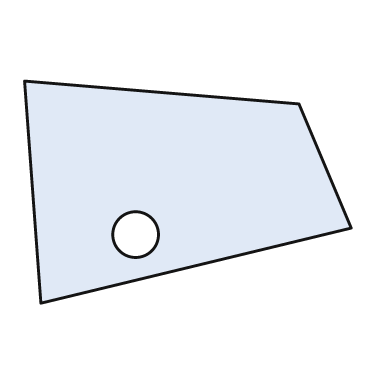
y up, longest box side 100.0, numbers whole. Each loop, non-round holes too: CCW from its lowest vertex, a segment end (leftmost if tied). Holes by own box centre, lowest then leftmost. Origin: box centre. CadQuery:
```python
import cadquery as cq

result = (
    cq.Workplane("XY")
    .moveTo(-45.0, -34.0)
    .lineTo(50.0, -11.0)
    .lineTo(34.0, 27.0)
    .lineTo(-50.0, 34.0)
    .close()
    .moveTo(-16.0, -13.0)
    .circle(7.0)
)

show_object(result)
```